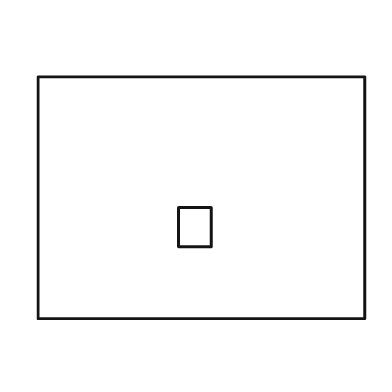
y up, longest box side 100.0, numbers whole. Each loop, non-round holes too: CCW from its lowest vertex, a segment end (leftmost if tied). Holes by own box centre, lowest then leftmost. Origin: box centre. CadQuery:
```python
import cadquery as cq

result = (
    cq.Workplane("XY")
    .moveTo(-50.0, -37.0)
    .lineTo(50.0, -37.0)
    .lineTo(50.0, 37.0)
    .lineTo(-50.0, 37.0)
    .close()
    .moveTo(-7.0, -15.0)
    .lineTo(3.0, -15.0)
    .lineTo(3.0, -3.0)
    .lineTo(-7.0, -3.0)
    .close()
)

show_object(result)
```